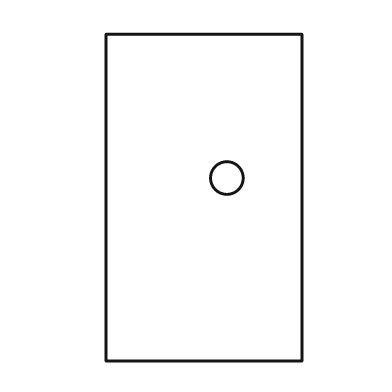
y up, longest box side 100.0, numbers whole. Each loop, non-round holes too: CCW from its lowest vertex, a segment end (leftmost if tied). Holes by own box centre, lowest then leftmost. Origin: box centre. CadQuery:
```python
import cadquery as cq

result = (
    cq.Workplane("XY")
    .moveTo(-30.0, -50.0)
    .lineTo(30.0, -50.0)
    .lineTo(30.0, 50.0)
    .lineTo(-30.0, 50.0)
    .close()
    .moveTo(7.0, 6.0)
    .circle(5.0)
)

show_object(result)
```